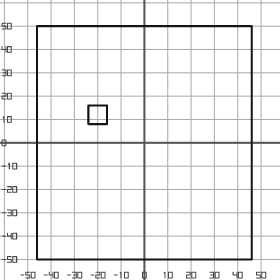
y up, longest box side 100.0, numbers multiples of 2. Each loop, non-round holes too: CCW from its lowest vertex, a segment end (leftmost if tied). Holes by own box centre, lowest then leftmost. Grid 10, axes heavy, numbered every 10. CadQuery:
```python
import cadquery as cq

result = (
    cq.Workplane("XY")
    .moveTo(-46.0, -50.0)
    .lineTo(46.0, -50.0)
    .lineTo(46.0, 50.0)
    .lineTo(-46.0, 50.0)
    .close()
    .moveTo(-24.0, 8.0)
    .lineTo(-16.0, 8.0)
    .lineTo(-16.0, 16.0)
    .lineTo(-24.0, 16.0)
    .close()
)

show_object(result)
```